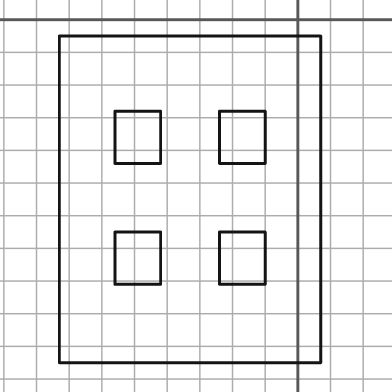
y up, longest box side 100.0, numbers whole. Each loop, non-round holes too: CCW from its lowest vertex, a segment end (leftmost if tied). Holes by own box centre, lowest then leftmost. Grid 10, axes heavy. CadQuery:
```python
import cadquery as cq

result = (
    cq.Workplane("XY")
    .moveTo(-73.0, -105.0)
    .lineTo(7.0, -105.0)
    .lineTo(7.0, -5.0)
    .lineTo(-73.0, -5.0)
    .close()
    .moveTo(-56.0, -81.0)
    .lineTo(-42.0, -81.0)
    .lineTo(-42.0, -65.0)
    .lineTo(-56.0, -65.0)
    .close()
    .moveTo(-24.0, -81.0)
    .lineTo(-10.0, -81.0)
    .lineTo(-10.0, -65.0)
    .lineTo(-24.0, -65.0)
    .close()
    .moveTo(-56.0, -44.0)
    .lineTo(-42.0, -44.0)
    .lineTo(-42.0, -28.0)
    .lineTo(-56.0, -28.0)
    .close()
    .moveTo(-24.0, -44.0)
    .lineTo(-10.0, -44.0)
    .lineTo(-10.0, -28.0)
    .lineTo(-24.0, -28.0)
    .close()
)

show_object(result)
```